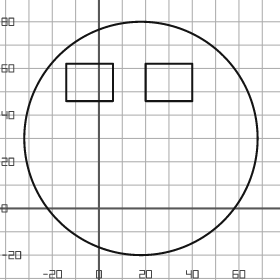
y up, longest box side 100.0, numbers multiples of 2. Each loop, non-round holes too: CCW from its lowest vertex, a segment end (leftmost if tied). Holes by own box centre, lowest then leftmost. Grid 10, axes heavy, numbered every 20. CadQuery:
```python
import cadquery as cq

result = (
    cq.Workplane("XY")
    .moveTo(18.0, 30.0)
    .circle(50.0)
    .moveTo(-14.0, 46.0)
    .lineTo(6.0, 46.0)
    .lineTo(6.0, 62.0)
    .lineTo(-14.0, 62.0)
    .close()
    .moveTo(20.0, 46.0)
    .lineTo(40.0, 46.0)
    .lineTo(40.0, 62.0)
    .lineTo(20.0, 62.0)
    .close()
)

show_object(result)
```